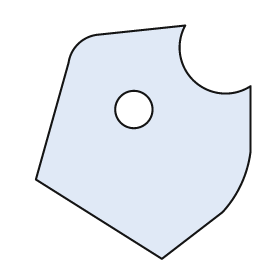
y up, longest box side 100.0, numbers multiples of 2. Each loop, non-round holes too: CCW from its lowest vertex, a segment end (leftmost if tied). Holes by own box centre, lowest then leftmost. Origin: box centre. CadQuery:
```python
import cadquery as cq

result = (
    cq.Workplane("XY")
    .moveTo(8.0, -50.0)
    .lineTo(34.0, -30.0)
    .threePointArc((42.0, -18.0), (46.0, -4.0))
    .lineTo(46.0, 24.0)
    .threePointArc((22.0, 26.0), (18.0, 50.0))
    .lineTo(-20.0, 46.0)
    .threePointArc((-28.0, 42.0), (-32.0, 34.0))
    .lineTo(-46.0, -16.0)
    .close()
    .moveTo(-4.0, 14.0)
    .circle(8.0)
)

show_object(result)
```